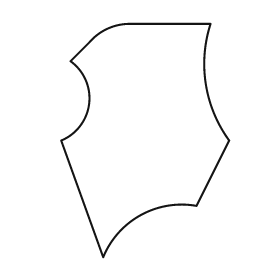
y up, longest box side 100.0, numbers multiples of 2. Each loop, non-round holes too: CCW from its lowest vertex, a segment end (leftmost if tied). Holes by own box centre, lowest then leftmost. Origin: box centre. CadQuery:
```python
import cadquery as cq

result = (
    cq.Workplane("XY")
    .moveTo(-18.0, -50.0)
    .threePointArc((-2.0, -32.0), (22.0, -28.0))
    .lineTo(36.0, 0.0)
    .threePointArc((26.0, 24.0), (28.0, 50.0))
    .lineTo(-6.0, 50.0)
    .threePointArc((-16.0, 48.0), (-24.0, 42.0))
    .lineTo(-32.0, 34.0)
    .threePointArc((-24.0, 16.0), (-36.0, 0.0))
    .close()
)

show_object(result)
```